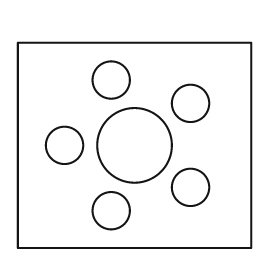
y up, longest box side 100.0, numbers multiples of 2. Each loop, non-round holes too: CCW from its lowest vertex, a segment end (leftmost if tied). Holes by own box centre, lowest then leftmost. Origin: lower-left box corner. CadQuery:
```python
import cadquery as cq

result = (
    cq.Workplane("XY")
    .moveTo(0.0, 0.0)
    .lineTo(100.0, 0.0)
    .lineTo(100.0, 88.0)
    .lineTo(0.0, 88.0)
    .close()
    .moveTo(40.0, 16.0)
    .circle(8.0)
    .moveTo(74.0, 26.0)
    .circle(8.0)
    .moveTo(20.0, 44.0)
    .circle(8.0)
    .moveTo(50.0, 44.0)
    .circle(16.0)
    .moveTo(74.0, 62.0)
    .circle(8.0)
    .moveTo(40.0, 72.0)
    .circle(8.0)
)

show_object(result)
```